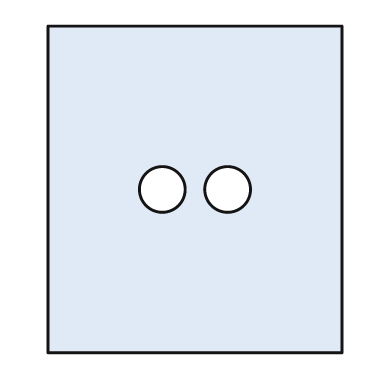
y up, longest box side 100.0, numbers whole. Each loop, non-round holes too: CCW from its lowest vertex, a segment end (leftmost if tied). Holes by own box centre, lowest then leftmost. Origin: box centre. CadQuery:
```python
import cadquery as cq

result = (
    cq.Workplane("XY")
    .moveTo(-45.0, -50.0)
    .lineTo(45.0, -50.0)
    .lineTo(45.0, 50.0)
    .lineTo(-45.0, 50.0)
    .close()
    .moveTo(-10.0, 0.0)
    .circle(7.0)
    .moveTo(10.0, 0.0)
    .circle(7.0)
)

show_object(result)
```